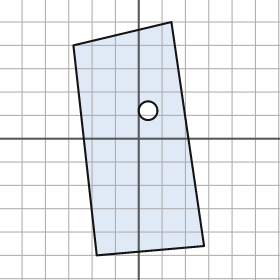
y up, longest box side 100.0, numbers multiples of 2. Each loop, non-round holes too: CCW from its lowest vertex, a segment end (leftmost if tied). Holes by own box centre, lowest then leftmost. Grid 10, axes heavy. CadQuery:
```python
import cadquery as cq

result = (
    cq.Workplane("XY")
    .moveTo(-18.0, -50.0)
    .lineTo(28.0, -46.0)
    .lineTo(14.0, 50.0)
    .lineTo(-28.0, 40.0)
    .close()
    .moveTo(4.0, 12.0)
    .circle(4.0)
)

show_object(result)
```